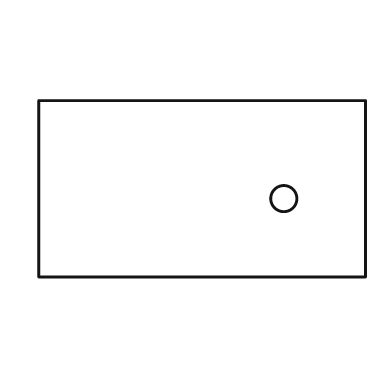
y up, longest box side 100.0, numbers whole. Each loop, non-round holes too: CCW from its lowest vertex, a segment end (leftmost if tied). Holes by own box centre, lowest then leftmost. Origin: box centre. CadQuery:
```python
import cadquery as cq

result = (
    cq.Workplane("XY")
    .moveTo(-50.0, -27.0)
    .lineTo(50.0, -27.0)
    .lineTo(50.0, 27.0)
    .lineTo(-50.0, 27.0)
    .close()
    .moveTo(25.0, -3.0)
    .circle(4.0)
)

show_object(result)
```